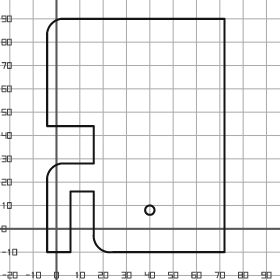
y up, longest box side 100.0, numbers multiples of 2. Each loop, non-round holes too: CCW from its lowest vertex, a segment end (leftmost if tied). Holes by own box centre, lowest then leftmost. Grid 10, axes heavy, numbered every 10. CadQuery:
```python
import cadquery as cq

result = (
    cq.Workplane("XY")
    .moveTo(-4.0, -10.0)
    .lineTo(6.0, -10.0)
    .lineTo(6.0, 16.0)
    .lineTo(16.0, 16.0)
    .lineTo(16.0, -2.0)
    .threePointArc((18.0, -8.0), (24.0, -10.0))
    .lineTo(72.0, -10.0)
    .lineTo(72.0, 90.0)
    .lineTo(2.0, 90.0)
    .threePointArc((-2.0, 88.0), (-4.0, 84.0))
    .lineTo(-4.0, 44.0)
    .lineTo(16.0, 44.0)
    .lineTo(16.0, 28.0)
    .lineTo(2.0, 28.0)
    .threePointArc((-2.0, 26.0), (-4.0, 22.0))
    .close()
    .moveTo(40.0, 8.0)
    .circle(2.0)
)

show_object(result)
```